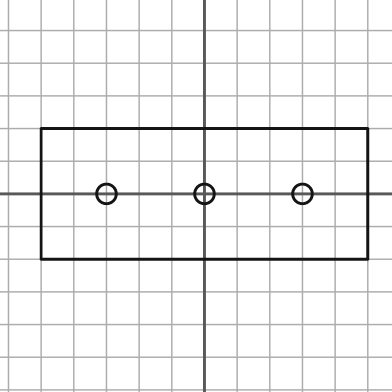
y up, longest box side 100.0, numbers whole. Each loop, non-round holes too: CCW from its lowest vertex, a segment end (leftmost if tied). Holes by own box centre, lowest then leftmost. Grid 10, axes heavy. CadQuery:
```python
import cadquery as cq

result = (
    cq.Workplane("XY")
    .moveTo(-50.0, -20.0)
    .lineTo(50.0, -20.0)
    .lineTo(50.0, 20.0)
    .lineTo(-50.0, 20.0)
    .close()
    .moveTo(-30.0, 0.0)
    .circle(3.0)
    .moveTo(0.0, 0.0)
    .circle(3.0)
    .moveTo(30.0, 0.0)
    .circle(3.0)
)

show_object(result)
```